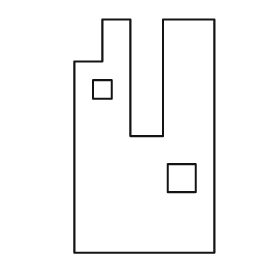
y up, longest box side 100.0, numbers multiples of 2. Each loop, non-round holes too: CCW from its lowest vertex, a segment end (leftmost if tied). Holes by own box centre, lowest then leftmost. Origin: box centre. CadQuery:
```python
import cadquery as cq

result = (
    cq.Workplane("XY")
    .moveTo(-30.0, -50.0)
    .lineTo(30.0, -50.0)
    .lineTo(30.0, 50.0)
    .lineTo(8.0, 50.0)
    .lineTo(8.0, 0.0)
    .lineTo(-6.0, 0.0)
    .lineTo(-6.0, 50.0)
    .lineTo(-18.0, 50.0)
    .lineTo(-18.0, 32.0)
    .lineTo(-30.0, 32.0)
    .close()
    .moveTo(10.0, -24.0)
    .lineTo(22.0, -24.0)
    .lineTo(22.0, -12.0)
    .lineTo(10.0, -12.0)
    .close()
    .moveTo(-22.0, 16.0)
    .lineTo(-14.0, 16.0)
    .lineTo(-14.0, 24.0)
    .lineTo(-22.0, 24.0)
    .close()
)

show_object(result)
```